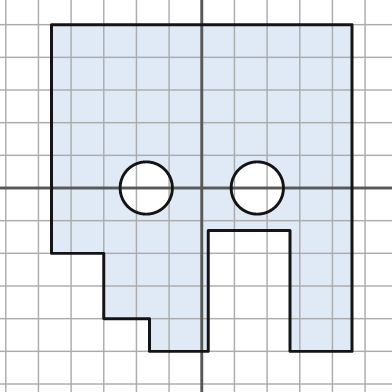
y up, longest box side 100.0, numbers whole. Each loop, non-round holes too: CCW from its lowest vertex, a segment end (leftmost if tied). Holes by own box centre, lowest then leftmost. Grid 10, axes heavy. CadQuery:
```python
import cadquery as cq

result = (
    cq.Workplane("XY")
    .moveTo(-16.0, -50.0)
    .lineTo(2.0, -50.0)
    .lineTo(2.0, -13.0)
    .lineTo(27.0, -13.0)
    .lineTo(27.0, -50.0)
    .lineTo(46.0, -50.0)
    .lineTo(46.0, 50.0)
    .lineTo(-46.0, 50.0)
    .lineTo(-46.0, -20.0)
    .lineTo(-30.0, -20.0)
    .lineTo(-30.0, -40.0)
    .lineTo(-16.0, -40.0)
    .close()
    .moveTo(-17.0, 0.0)
    .circle(8.0)
    .moveTo(17.0, 0.0)
    .circle(8.0)
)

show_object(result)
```